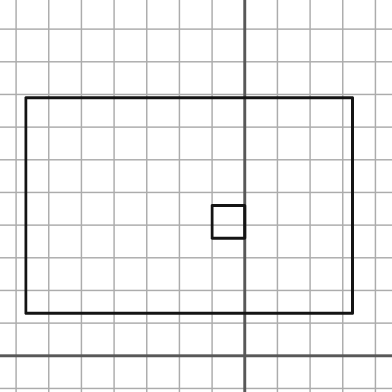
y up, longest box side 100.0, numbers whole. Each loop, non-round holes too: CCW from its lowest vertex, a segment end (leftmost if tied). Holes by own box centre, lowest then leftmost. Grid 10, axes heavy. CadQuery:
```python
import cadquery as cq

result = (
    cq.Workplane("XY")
    .moveTo(-67.0, 13.0)
    .lineTo(33.0, 13.0)
    .lineTo(33.0, 79.0)
    .lineTo(-67.0, 79.0)
    .close()
    .moveTo(-10.0, 36.0)
    .lineTo(0.0, 36.0)
    .lineTo(0.0, 46.0)
    .lineTo(-10.0, 46.0)
    .close()
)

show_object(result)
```